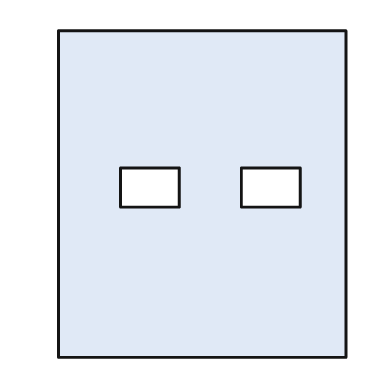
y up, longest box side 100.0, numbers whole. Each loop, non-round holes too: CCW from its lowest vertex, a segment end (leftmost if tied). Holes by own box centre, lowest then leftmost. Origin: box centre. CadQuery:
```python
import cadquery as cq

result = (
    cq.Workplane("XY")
    .moveTo(-44.0, -50.0)
    .lineTo(44.0, -50.0)
    .lineTo(44.0, 50.0)
    .lineTo(-44.0, 50.0)
    .close()
    .moveTo(-25.0, -4.0)
    .lineTo(-7.0, -4.0)
    .lineTo(-7.0, 8.0)
    .lineTo(-25.0, 8.0)
    .close()
    .moveTo(12.0, -4.0)
    .lineTo(30.0, -4.0)
    .lineTo(30.0, 8.0)
    .lineTo(12.0, 8.0)
    .close()
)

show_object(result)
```